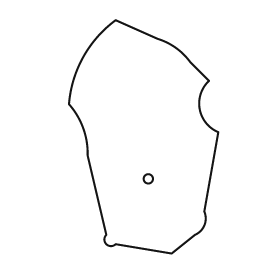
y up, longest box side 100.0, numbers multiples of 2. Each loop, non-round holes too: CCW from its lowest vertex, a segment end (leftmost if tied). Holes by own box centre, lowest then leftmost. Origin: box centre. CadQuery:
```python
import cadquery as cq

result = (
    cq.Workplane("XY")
    .moveTo(12.0, -50.0)
    .lineTo(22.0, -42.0)
    .threePointArc((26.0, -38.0), (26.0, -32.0))
    .lineTo(32.0, 2.0)
    .threePointArc((24.0, 12.0), (28.0, 24.0))
    .lineTo(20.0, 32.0)
    .threePointArc((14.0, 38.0), (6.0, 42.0))
    .lineTo(-12.0, 50.0)
    .threePointArc((-26.0, 34.0), (-32.0, 14.0))
    .threePointArc((-26.0, 4.0), (-24.0, -8.0))
    .lineTo(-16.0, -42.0)
    .threePointArc((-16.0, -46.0), (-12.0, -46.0))
    .close()
    .moveTo(2.0, -18.0)
    .circle(2.0)
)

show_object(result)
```